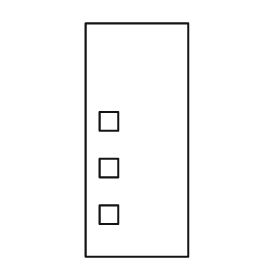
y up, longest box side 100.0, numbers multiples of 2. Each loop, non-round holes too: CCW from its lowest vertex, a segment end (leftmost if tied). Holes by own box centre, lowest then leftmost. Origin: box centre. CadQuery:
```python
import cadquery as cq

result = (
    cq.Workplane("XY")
    .moveTo(-22.0, -50.0)
    .lineTo(22.0, -50.0)
    .lineTo(22.0, 50.0)
    .lineTo(-22.0, 50.0)
    .close()
    .moveTo(-16.0, -36.0)
    .lineTo(-8.0, -36.0)
    .lineTo(-8.0, -28.0)
    .lineTo(-16.0, -28.0)
    .close()
    .moveTo(-16.0, -16.0)
    .lineTo(-8.0, -16.0)
    .lineTo(-8.0, -8.0)
    .lineTo(-16.0, -8.0)
    .close()
    .moveTo(-16.0, 4.0)
    .lineTo(-8.0, 4.0)
    .lineTo(-8.0, 12.0)
    .lineTo(-16.0, 12.0)
    .close()
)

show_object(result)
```